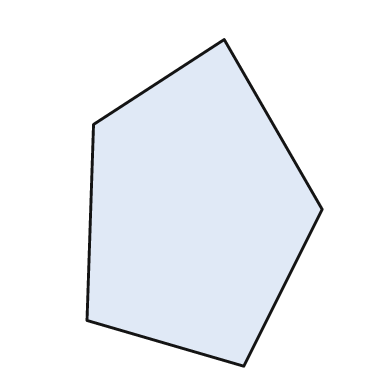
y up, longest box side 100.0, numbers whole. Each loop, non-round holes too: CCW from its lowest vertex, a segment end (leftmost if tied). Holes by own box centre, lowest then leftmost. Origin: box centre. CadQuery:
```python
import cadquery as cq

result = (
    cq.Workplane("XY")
    .moveTo(12.0, -50.0)
    .lineTo(36.0, -2.0)
    .lineTo(6.0, 50.0)
    .lineTo(-34.0, 24.0)
    .lineTo(-36.0, -36.0)
    .close()
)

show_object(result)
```